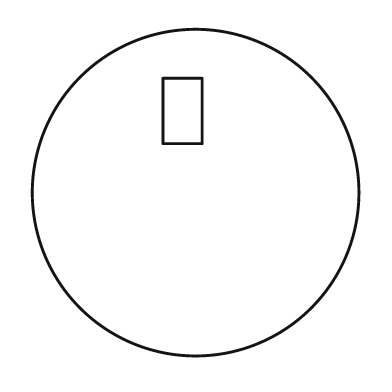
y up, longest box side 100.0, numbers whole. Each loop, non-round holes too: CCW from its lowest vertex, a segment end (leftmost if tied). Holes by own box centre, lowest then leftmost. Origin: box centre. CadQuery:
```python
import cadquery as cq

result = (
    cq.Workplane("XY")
    .moveTo(0.0, 0.0)
    .circle(50.0)
    .moveTo(-10.0, 15.0)
    .lineTo(2.0, 15.0)
    .lineTo(2.0, 35.0)
    .lineTo(-10.0, 35.0)
    .close()
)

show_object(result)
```